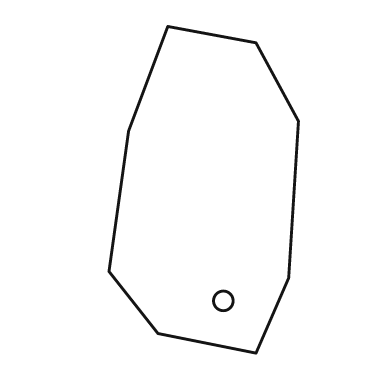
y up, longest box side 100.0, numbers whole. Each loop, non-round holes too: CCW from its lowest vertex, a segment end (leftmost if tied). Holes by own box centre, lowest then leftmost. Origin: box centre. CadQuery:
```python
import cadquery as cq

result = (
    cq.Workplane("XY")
    .moveTo(16.0, -50.0)
    .lineTo(26.0, -27.0)
    .lineTo(29.0, 21.0)
    .lineTo(16.0, 45.0)
    .lineTo(-11.0, 50.0)
    .lineTo(-23.0, 18.0)
    .lineTo(-29.0, -25.0)
    .lineTo(-14.0, -44.0)
    .close()
    .moveTo(6.0, -34.0)
    .circle(3.0)
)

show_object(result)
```